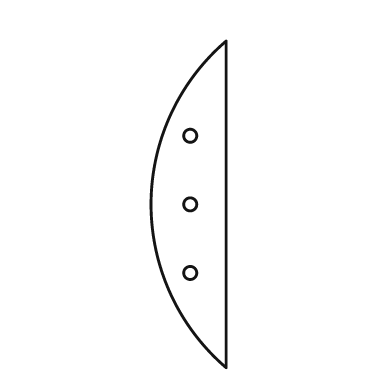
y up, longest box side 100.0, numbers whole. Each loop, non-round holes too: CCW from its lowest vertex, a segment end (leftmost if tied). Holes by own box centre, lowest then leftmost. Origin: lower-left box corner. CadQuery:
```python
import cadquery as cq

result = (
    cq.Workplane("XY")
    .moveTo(23.0, 0.0)
    .lineTo(23.0, 100.0)
    .threePointArc((0.0, 50.0), (23.0, 0.0))
    .close()
    .moveTo(12.0, 29.0)
    .circle(2.0)
    .moveTo(12.0, 50.0)
    .circle(2.0)
    .moveTo(12.0, 71.0)
    .circle(2.0)
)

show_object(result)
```